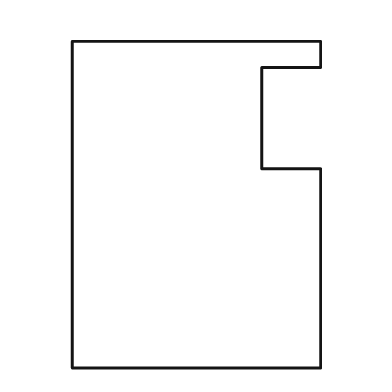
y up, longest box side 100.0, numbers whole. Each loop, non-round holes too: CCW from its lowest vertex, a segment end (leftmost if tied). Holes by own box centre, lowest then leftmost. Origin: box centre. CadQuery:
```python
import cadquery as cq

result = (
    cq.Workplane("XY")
    .moveTo(-38.0, -50.0)
    .lineTo(38.0, -50.0)
    .lineTo(38.0, 11.0)
    .lineTo(20.0, 11.0)
    .lineTo(20.0, 42.0)
    .lineTo(38.0, 42.0)
    .lineTo(38.0, 50.0)
    .lineTo(-38.0, 50.0)
    .close()
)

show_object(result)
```